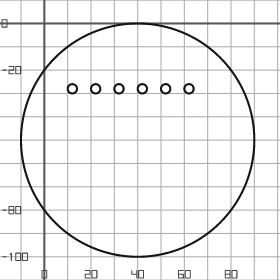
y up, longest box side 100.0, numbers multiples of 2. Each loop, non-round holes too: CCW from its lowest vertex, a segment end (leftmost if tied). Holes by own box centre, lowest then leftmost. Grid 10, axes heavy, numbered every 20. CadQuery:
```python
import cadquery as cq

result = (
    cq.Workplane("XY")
    .moveTo(40.0, -50.0)
    .circle(50.0)
    .moveTo(12.0, -28.0)
    .circle(2.0)
    .moveTo(22.0, -28.0)
    .circle(2.0)
    .moveTo(32.0, -28.0)
    .circle(2.0)
    .moveTo(42.0, -28.0)
    .circle(2.0)
    .moveTo(52.0, -28.0)
    .circle(2.0)
    .moveTo(62.0, -28.0)
    .circle(2.0)
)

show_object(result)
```